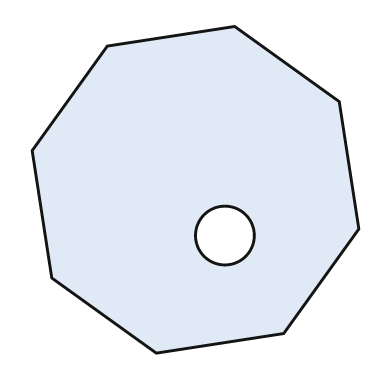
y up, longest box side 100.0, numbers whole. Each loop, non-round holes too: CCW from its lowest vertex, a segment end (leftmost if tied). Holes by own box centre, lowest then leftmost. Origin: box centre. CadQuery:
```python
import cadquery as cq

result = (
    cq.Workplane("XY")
    .moveTo(-12.0, -50.0)
    .lineTo(27.0, -44.0)
    .lineTo(50.0, -12.0)
    .lineTo(44.0, 27.0)
    .lineTo(12.0, 50.0)
    .lineTo(-27.0, 44.0)
    .lineTo(-50.0, 12.0)
    .lineTo(-44.0, -27.0)
    .close()
    .moveTo(9.0, -14.0)
    .circle(9.0)
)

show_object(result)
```